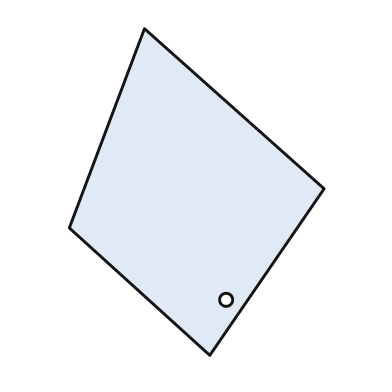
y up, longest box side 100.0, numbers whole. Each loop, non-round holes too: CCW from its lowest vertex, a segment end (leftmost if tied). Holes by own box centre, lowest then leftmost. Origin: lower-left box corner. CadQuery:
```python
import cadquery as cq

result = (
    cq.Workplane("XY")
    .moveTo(43.0, 0.0)
    .lineTo(78.0, 51.0)
    .lineTo(23.0, 100.0)
    .lineTo(0.0, 39.0)
    .close()
    .moveTo(48.0, 17.0)
    .circle(2.0)
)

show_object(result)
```